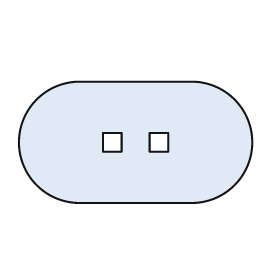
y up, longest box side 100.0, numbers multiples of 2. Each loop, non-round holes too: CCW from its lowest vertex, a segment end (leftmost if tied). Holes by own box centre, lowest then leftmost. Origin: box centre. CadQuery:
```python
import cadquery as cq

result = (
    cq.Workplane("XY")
    .moveTo(-24.0, -26.0)
    .lineTo(24.0, -26.0)
    .threePointArc((50.0, 0.0), (24.0, 26.0))
    .lineTo(-24.0, 26.0)
    .threePointArc((-50.0, 0.0), (-24.0, -26.0))
    .close()
    .moveTo(-14.0, -4.0)
    .lineTo(-6.0, -4.0)
    .lineTo(-6.0, 4.0)
    .lineTo(-14.0, 4.0)
    .close()
    .moveTo(6.0, -4.0)
    .lineTo(14.0, -4.0)
    .lineTo(14.0, 4.0)
    .lineTo(6.0, 4.0)
    .close()
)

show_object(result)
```